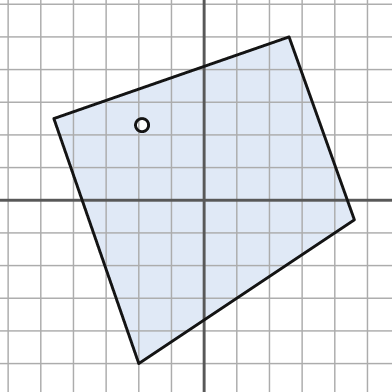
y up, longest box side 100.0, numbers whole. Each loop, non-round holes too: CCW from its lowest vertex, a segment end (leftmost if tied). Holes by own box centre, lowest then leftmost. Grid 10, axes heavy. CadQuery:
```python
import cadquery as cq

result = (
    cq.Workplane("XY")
    .moveTo(-20.0, -50.0)
    .lineTo(46.0, -6.0)
    .lineTo(26.0, 50.0)
    .lineTo(-46.0, 25.0)
    .close()
    .moveTo(-19.0, 23.0)
    .circle(2.0)
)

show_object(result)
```